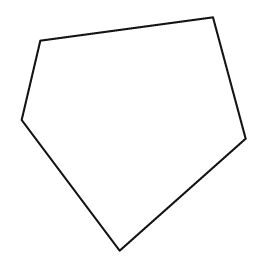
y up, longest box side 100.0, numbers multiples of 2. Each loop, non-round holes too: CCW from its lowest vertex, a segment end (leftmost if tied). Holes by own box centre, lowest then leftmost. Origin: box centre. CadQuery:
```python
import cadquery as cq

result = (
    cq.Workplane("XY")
    .moveTo(-6.0, -50.0)
    .lineTo(48.0, -2.0)
    .lineTo(34.0, 50.0)
    .lineTo(-40.0, 40.0)
    .lineTo(-48.0, 6.0)
    .close()
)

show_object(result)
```